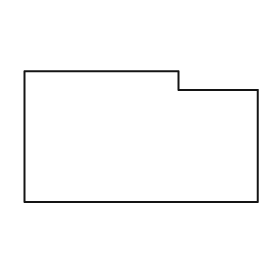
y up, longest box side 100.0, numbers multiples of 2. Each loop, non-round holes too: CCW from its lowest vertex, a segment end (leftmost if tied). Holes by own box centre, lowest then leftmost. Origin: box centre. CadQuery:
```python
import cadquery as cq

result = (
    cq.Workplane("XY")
    .moveTo(-50.0, -28.0)
    .lineTo(50.0, -28.0)
    .lineTo(50.0, 20.0)
    .lineTo(16.0, 20.0)
    .lineTo(16.0, 28.0)
    .lineTo(-50.0, 28.0)
    .close()
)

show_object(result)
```